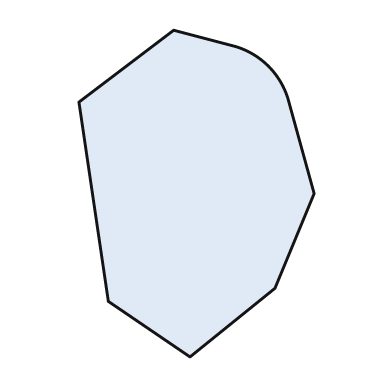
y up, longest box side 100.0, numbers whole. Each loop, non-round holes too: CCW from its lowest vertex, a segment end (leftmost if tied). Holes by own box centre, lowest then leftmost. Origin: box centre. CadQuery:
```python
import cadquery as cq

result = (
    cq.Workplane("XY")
    .moveTo(-2.0, -50.0)
    .lineTo(24.0, -29.0)
    .lineTo(36.0, 0.0)
    .lineTo(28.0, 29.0)
    .threePointArc((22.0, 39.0), (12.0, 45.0))
    .lineTo(-7.0, 50.0)
    .lineTo(-36.0, 28.0)
    .lineTo(-27.0, -33.0)
    .close()
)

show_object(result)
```